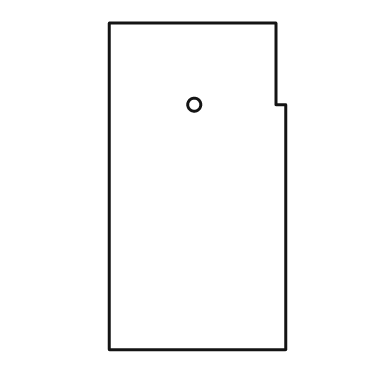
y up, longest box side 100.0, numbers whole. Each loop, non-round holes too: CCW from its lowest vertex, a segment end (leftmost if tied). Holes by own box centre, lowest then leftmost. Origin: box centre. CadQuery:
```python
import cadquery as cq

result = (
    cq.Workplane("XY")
    .moveTo(-27.0, -50.0)
    .lineTo(27.0, -50.0)
    .lineTo(27.0, 25.0)
    .lineTo(24.0, 25.0)
    .lineTo(24.0, 50.0)
    .lineTo(-27.0, 50.0)
    .close()
    .moveTo(-1.0, 25.0)
    .circle(2.0)
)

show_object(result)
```